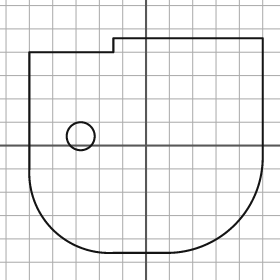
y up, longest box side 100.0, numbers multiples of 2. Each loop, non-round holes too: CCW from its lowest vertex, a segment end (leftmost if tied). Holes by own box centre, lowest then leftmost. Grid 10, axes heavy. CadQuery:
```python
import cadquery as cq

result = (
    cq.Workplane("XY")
    .moveTo(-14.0, -46.0)
    .lineTo(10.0, -46.0)
    .threePointArc((38.0, -34.0), (50.0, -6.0))
    .lineTo(50.0, 46.0)
    .lineTo(-14.0, 46.0)
    .lineTo(-14.0, 40.0)
    .lineTo(-50.0, 40.0)
    .lineTo(-50.0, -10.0)
    .threePointArc((-40.0, -36.0), (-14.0, -46.0))
    .close()
    .moveTo(-28.0, 4.0)
    .circle(6.0)
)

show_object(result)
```